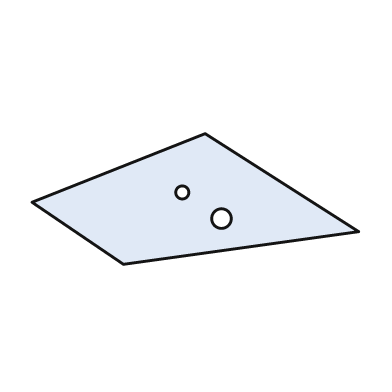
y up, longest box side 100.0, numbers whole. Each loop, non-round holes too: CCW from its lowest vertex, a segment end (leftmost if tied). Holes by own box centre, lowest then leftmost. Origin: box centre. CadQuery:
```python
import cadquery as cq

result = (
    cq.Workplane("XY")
    .moveTo(-22.0, -20.0)
    .lineTo(50.0, -10.0)
    .lineTo(3.0, 20.0)
    .lineTo(-50.0, -1.0)
    .close()
    .moveTo(8.0, -6.0)
    .circle(3.0)
    .moveTo(-4.0, 2.0)
    .circle(2.0)
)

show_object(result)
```